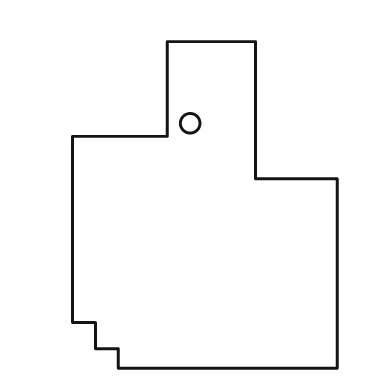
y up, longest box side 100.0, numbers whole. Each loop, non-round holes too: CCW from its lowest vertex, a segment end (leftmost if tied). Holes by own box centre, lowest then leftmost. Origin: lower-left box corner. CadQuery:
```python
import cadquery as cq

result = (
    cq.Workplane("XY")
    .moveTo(14.0, 0.0)
    .lineTo(81.0, 0.0)
    .lineTo(81.0, 58.0)
    .lineTo(56.0, 58.0)
    .lineTo(56.0, 100.0)
    .lineTo(29.0, 100.0)
    .lineTo(29.0, 71.0)
    .lineTo(0.0, 71.0)
    .lineTo(0.0, 14.0)
    .lineTo(7.0, 14.0)
    .lineTo(7.0, 6.0)
    .lineTo(14.0, 6.0)
    .close()
    .moveTo(36.0, 75.0)
    .circle(3.0)
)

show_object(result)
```